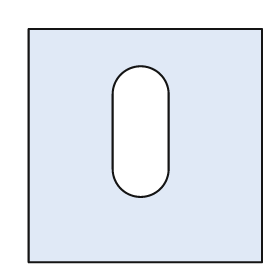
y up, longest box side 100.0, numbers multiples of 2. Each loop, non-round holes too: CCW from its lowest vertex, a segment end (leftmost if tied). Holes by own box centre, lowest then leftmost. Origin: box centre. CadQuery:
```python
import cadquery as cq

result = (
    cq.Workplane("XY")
    .moveTo(-50.0, -50.0)
    .lineTo(50.0, -50.0)
    .lineTo(50.0, 50.0)
    .lineTo(-50.0, 50.0)
    .close()
    .moveTo(-14.0, -10.0)
    .threePointArc((-2.0, -22.0), (10.0, -10.0))
    .lineTo(10.0, 22.0)
    .threePointArc((-2.0, 34.0), (-14.0, 22.0))
    .close()
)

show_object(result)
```